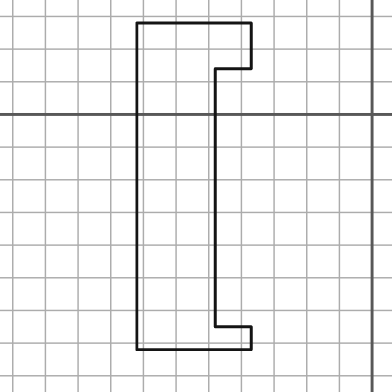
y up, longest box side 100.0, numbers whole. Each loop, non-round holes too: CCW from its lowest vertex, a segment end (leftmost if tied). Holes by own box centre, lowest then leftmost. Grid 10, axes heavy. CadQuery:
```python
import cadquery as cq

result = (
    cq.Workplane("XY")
    .moveTo(-72.0, -72.0)
    .lineTo(-37.0, -72.0)
    .lineTo(-37.0, -65.0)
    .lineTo(-48.0, -65.0)
    .lineTo(-48.0, 14.0)
    .lineTo(-37.0, 14.0)
    .lineTo(-37.0, 28.0)
    .lineTo(-72.0, 28.0)
    .close()
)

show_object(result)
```